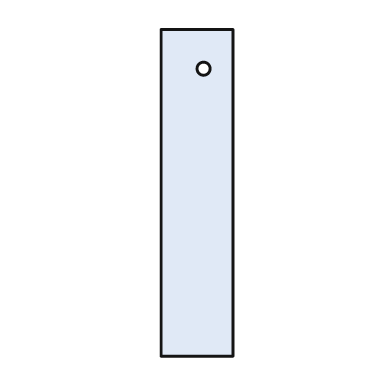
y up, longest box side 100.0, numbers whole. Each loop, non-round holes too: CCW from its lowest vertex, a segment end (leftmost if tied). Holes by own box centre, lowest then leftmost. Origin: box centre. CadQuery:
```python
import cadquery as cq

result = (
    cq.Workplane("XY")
    .moveTo(-11.0, -50.0)
    .lineTo(11.0, -50.0)
    .lineTo(11.0, 50.0)
    .lineTo(-11.0, 50.0)
    .close()
    .moveTo(2.0, 38.0)
    .circle(2.0)
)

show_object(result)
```